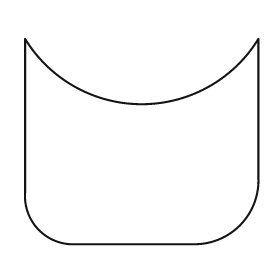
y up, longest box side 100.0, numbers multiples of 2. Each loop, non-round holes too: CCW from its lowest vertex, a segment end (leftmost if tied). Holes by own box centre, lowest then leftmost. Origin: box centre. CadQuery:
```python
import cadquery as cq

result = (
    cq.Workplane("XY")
    .moveTo(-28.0, -44.0)
    .lineTo(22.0, -44.0)
    .threePointArc((42.0, -36.0), (50.0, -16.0))
    .lineTo(50.0, 44.0)
    .threePointArc((0.0, 16.0), (-50.0, 44.0))
    .lineTo(-50.0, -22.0)
    .threePointArc((-44.0, -38.0), (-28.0, -44.0))
    .close()
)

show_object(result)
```